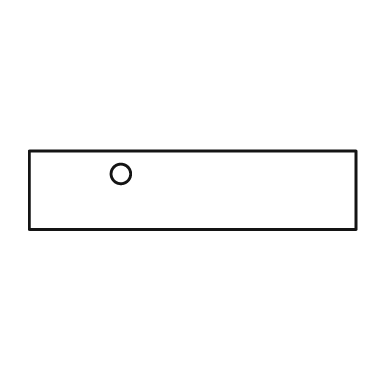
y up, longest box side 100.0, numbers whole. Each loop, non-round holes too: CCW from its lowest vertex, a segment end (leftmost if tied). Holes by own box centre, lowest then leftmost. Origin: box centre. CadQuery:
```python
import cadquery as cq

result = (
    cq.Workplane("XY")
    .moveTo(-50.0, -12.0)
    .lineTo(50.0, -12.0)
    .lineTo(50.0, 12.0)
    .lineTo(-50.0, 12.0)
    .close()
    .moveTo(-22.0, 5.0)
    .circle(3.0)
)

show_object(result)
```